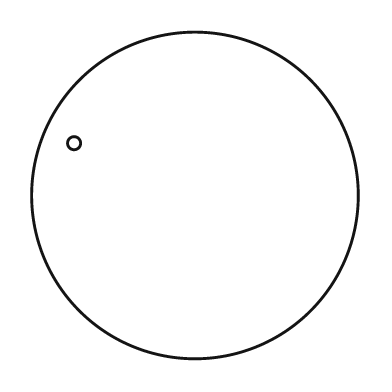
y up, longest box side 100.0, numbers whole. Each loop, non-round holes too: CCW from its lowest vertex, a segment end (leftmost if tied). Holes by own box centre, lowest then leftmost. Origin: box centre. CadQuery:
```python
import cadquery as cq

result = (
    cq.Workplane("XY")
    .moveTo(0.0, 0.0)
    .circle(50.0)
    .moveTo(-37.0, 16.0)
    .circle(2.0)
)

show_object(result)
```